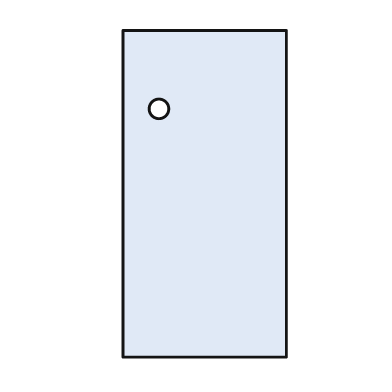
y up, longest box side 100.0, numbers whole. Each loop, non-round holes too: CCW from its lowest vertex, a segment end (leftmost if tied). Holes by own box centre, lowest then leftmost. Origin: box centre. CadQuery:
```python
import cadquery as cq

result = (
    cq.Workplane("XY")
    .moveTo(-25.0, -50.0)
    .lineTo(25.0, -50.0)
    .lineTo(25.0, 50.0)
    .lineTo(-25.0, 50.0)
    .close()
    .moveTo(-14.0, 26.0)
    .circle(3.0)
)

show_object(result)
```